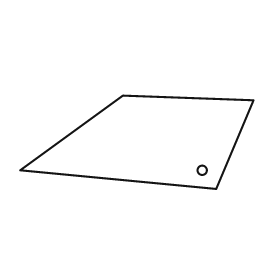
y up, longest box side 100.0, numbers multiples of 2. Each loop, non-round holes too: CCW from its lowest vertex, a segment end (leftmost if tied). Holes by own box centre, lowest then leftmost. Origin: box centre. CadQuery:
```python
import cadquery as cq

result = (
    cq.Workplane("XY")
    .moveTo(34.0, -20.0)
    .lineTo(50.0, 18.0)
    .lineTo(-6.0, 20.0)
    .lineTo(-50.0, -12.0)
    .close()
    .moveTo(28.0, -12.0)
    .circle(2.0)
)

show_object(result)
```